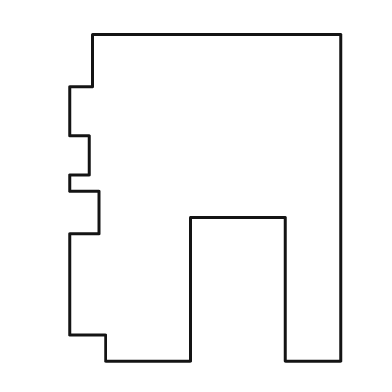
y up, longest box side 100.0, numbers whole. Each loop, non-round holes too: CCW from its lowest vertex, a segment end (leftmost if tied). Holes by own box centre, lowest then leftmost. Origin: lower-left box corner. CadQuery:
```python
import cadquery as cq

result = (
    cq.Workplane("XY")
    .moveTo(11.0, 0.0)
    .lineTo(37.0, 0.0)
    .lineTo(37.0, 44.0)
    .lineTo(66.0, 44.0)
    .lineTo(66.0, 0.0)
    .lineTo(83.0, 0.0)
    .lineTo(83.0, 100.0)
    .lineTo(7.0, 100.0)
    .lineTo(7.0, 84.0)
    .lineTo(0.0, 84.0)
    .lineTo(0.0, 69.0)
    .lineTo(6.0, 69.0)
    .lineTo(6.0, 57.0)
    .lineTo(0.0, 57.0)
    .lineTo(0.0, 52.0)
    .lineTo(9.0, 52.0)
    .lineTo(9.0, 39.0)
    .lineTo(0.0, 39.0)
    .lineTo(0.0, 8.0)
    .lineTo(11.0, 8.0)
    .close()
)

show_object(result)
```